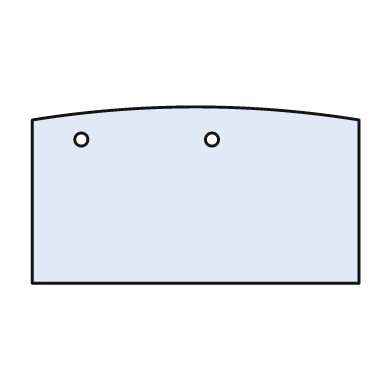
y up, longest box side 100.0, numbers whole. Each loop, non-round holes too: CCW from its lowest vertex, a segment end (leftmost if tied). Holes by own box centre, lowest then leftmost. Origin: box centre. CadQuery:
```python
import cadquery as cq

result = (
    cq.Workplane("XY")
    .moveTo(-50.0, -27.0)
    .lineTo(50.0, -27.0)
    .lineTo(50.0, 23.0)
    .threePointArc((0.0, 27.0), (-50.0, 23.0))
    .close()
    .moveTo(-35.0, 17.0)
    .circle(2.0)
    .moveTo(5.0, 17.0)
    .circle(2.0)
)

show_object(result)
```